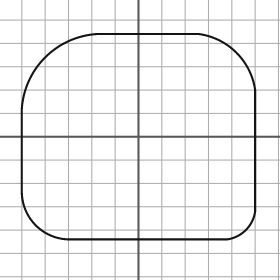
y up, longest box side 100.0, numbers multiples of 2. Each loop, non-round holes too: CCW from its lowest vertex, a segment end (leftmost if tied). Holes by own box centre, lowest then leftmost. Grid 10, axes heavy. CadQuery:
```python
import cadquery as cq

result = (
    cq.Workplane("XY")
    .moveTo(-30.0, -44.0)
    .lineTo(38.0, -44.0)
    .threePointArc((46.0, -40.0), (50.0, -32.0))
    .lineTo(50.0, 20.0)
    .threePointArc((42.0, 36.0), (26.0, 44.0))
    .lineTo(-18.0, 44.0)
    .threePointArc((-40.0, 34.0), (-50.0, 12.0))
    .lineTo(-50.0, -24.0)
    .threePointArc((-44.0, -38.0), (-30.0, -44.0))
    .close()
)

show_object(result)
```